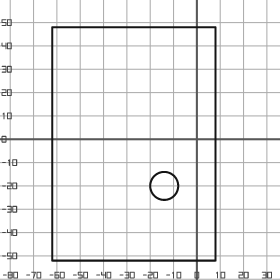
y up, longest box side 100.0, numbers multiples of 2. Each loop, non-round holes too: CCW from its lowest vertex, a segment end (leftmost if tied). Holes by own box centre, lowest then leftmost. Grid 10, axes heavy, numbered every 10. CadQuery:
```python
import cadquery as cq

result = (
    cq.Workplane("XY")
    .moveTo(-62.0, -52.0)
    .lineTo(8.0, -52.0)
    .lineTo(8.0, 48.0)
    .lineTo(-62.0, 48.0)
    .close()
    .moveTo(-14.0, -20.0)
    .circle(6.0)
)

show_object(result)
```